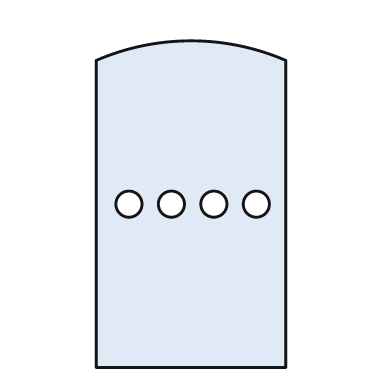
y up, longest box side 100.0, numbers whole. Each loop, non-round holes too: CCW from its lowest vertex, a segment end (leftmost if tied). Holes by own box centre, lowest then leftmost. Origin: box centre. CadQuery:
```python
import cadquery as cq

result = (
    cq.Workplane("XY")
    .moveTo(-29.0, -50.0)
    .lineTo(29.0, -50.0)
    .lineTo(29.0, 44.0)
    .threePointArc((0.0, 50.0), (-29.0, 44.0))
    .close()
    .moveTo(-19.0, 0.0)
    .circle(4.0)
    .moveTo(-6.0, 0.0)
    .circle(4.0)
    .moveTo(7.0, 0.0)
    .circle(4.0)
    .moveTo(20.0, 0.0)
    .circle(4.0)
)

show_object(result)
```